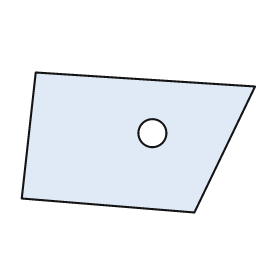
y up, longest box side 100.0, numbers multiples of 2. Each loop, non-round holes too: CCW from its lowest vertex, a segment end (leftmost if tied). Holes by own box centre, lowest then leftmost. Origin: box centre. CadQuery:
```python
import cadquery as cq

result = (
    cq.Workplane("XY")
    .moveTo(24.0, -30.0)
    .lineTo(50.0, 24.0)
    .lineTo(-44.0, 30.0)
    .lineTo(-50.0, -24.0)
    .close()
    .moveTo(6.0, 4.0)
    .circle(6.0)
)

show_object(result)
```